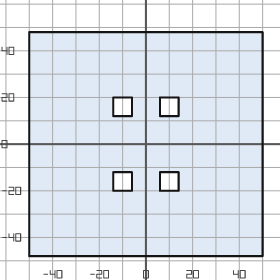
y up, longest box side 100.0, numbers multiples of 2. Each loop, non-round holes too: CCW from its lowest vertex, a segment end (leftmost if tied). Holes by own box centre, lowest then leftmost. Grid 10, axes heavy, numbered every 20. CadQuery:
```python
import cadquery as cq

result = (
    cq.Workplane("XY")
    .moveTo(-50.0, -48.0)
    .lineTo(50.0, -48.0)
    .lineTo(50.0, 48.0)
    .lineTo(-50.0, 48.0)
    .close()
    .moveTo(-14.0, -20.0)
    .lineTo(-6.0, -20.0)
    .lineTo(-6.0, -12.0)
    .lineTo(-14.0, -12.0)
    .close()
    .moveTo(6.0, -20.0)
    .lineTo(14.0, -20.0)
    .lineTo(14.0, -12.0)
    .lineTo(6.0, -12.0)
    .close()
    .moveTo(-14.0, 12.0)
    .lineTo(-6.0, 12.0)
    .lineTo(-6.0, 20.0)
    .lineTo(-14.0, 20.0)
    .close()
    .moveTo(6.0, 12.0)
    .lineTo(14.0, 12.0)
    .lineTo(14.0, 20.0)
    .lineTo(6.0, 20.0)
    .close()
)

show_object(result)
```